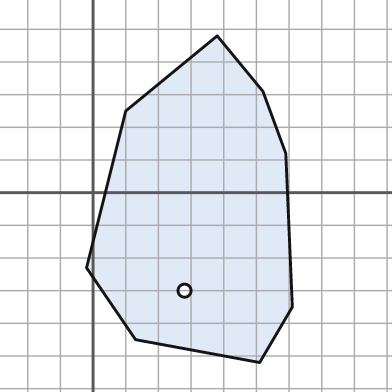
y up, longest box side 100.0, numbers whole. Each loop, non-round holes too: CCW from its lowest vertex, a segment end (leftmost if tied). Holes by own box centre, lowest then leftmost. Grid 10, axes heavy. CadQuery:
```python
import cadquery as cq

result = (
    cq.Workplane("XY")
    .moveTo(51.0, -52.0)
    .lineTo(61.0, -35.0)
    .lineTo(59.0, 12.0)
    .lineTo(52.0, 31.0)
    .lineTo(38.0, 48.0)
    .lineTo(10.0, 25.0)
    .lineTo(-2.0, -23.0)
    .lineTo(13.0, -45.0)
    .close()
    .moveTo(28.0, -30.0)
    .circle(2.0)
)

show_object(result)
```